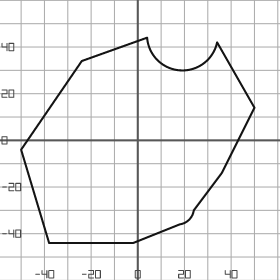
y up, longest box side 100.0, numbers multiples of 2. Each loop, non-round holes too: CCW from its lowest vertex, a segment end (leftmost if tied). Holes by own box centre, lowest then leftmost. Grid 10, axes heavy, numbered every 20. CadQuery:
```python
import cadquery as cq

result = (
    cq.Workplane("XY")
    .moveTo(-38.0, -44.0)
    .lineTo(-2.0, -44.0)
    .lineTo(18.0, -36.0)
    .threePointArc((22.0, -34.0), (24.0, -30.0))
    .lineTo(36.0, -14.0)
    .lineTo(50.0, 14.0)
    .lineTo(34.0, 42.0)
    .threePointArc((18.0, 30.0), (4.0, 44.0))
    .lineTo(-24.0, 34.0)
    .lineTo(-50.0, -4.0)
    .close()
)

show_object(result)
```